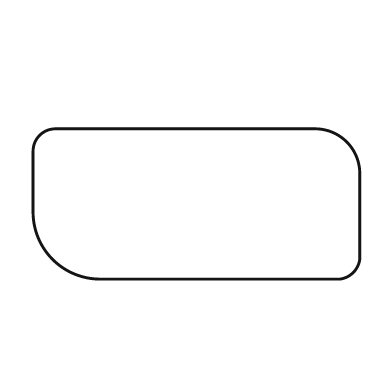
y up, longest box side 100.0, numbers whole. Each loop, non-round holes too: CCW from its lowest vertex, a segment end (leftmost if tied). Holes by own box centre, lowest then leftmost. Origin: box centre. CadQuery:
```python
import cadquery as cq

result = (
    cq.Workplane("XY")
    .moveTo(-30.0, -23.0)
    .lineTo(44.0, -23.0)
    .threePointArc((48.0, -21.0), (50.0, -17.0))
    .lineTo(50.0, 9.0)
    .threePointArc((46.0, 19.0), (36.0, 23.0))
    .lineTo(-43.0, 23.0)
    .threePointArc((-48.0, 21.0), (-50.0, 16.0))
    .lineTo(-50.0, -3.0)
    .threePointArc((-44.0, -17.0), (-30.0, -23.0))
    .close()
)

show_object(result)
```